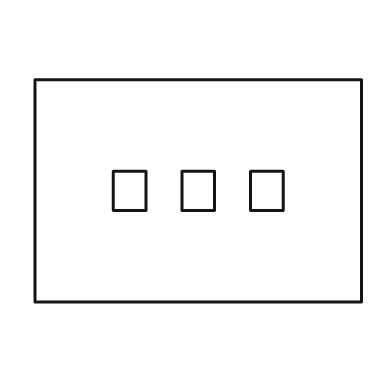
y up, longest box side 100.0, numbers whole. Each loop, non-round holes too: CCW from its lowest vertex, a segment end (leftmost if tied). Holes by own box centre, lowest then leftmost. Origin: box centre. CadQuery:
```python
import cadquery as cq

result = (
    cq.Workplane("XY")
    .moveTo(-50.0, -34.0)
    .lineTo(50.0, -34.0)
    .lineTo(50.0, 34.0)
    .lineTo(-50.0, 34.0)
    .close()
    .moveTo(-26.0, -6.0)
    .lineTo(-16.0, -6.0)
    .lineTo(-16.0, 6.0)
    .lineTo(-26.0, 6.0)
    .close()
    .moveTo(-5.0, -6.0)
    .lineTo(5.0, -6.0)
    .lineTo(5.0, 6.0)
    .lineTo(-5.0, 6.0)
    .close()
    .moveTo(16.0, -6.0)
    .lineTo(26.0, -6.0)
    .lineTo(26.0, 6.0)
    .lineTo(16.0, 6.0)
    .close()
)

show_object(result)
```